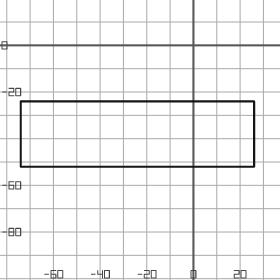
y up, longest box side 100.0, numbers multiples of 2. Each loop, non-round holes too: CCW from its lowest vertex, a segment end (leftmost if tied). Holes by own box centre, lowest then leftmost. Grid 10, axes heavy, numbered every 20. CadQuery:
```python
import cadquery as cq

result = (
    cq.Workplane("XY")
    .moveTo(-74.0, -52.0)
    .lineTo(26.0, -52.0)
    .lineTo(26.0, -24.0)
    .lineTo(-74.0, -24.0)
    .close()
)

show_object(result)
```